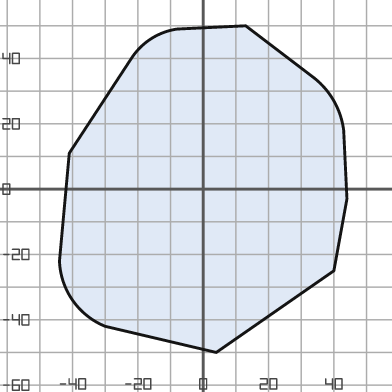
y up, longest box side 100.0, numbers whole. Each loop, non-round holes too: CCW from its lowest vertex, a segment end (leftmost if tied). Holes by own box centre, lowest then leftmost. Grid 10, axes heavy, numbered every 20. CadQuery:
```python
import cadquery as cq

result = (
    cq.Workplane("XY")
    .moveTo(4.0, -50.0)
    .lineTo(40.0, -25.0)
    .lineTo(44.0, -3.0)
    .lineTo(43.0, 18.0)
    .threePointArc((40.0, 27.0), (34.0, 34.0))
    .lineTo(13.0, 50.0)
    .lineTo(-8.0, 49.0)
    .threePointArc((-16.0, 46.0), (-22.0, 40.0))
    .lineTo(-41.0, 11.0)
    .lineTo(-44.0, -22.0)
    .threePointArc((-40.0, -34.0), (-30.0, -42.0))
    .close()
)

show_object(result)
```